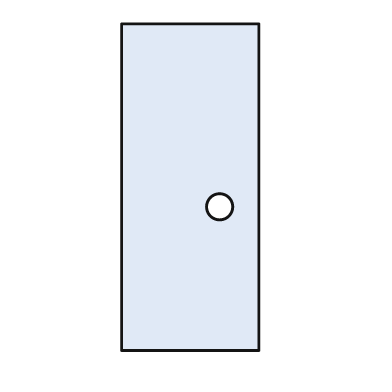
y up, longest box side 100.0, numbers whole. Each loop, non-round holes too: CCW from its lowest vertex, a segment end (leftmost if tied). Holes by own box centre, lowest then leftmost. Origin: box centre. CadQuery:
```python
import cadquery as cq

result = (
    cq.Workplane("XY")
    .moveTo(-21.0, -50.0)
    .lineTo(21.0, -50.0)
    .lineTo(21.0, 50.0)
    .lineTo(-21.0, 50.0)
    .close()
    .moveTo(9.0, -6.0)
    .circle(4.0)
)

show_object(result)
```